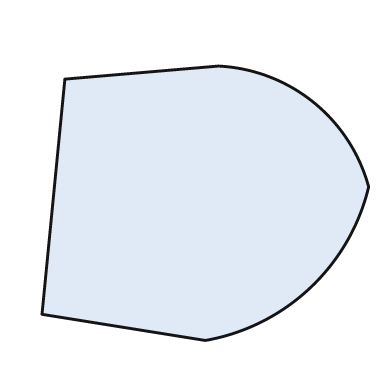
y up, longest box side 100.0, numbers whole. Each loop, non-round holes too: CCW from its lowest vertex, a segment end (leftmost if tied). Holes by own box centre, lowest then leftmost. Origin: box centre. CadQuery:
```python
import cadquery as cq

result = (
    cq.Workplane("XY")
    .moveTo(0.0, -42.0)
    .threePointArc((32.0, -26.0), (50.0, 5.0))
    .threePointArc((33.0, 31.0), (4.0, 42.0))
    .lineTo(-43.0, 38.0)
    .lineTo(-50.0, -34.0)
    .close()
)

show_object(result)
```